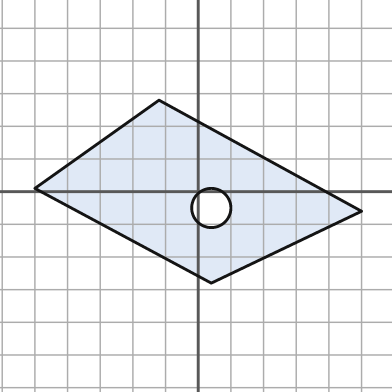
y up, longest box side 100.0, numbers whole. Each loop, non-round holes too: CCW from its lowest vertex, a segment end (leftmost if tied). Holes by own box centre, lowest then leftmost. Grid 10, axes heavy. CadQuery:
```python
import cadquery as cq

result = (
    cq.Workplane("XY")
    .moveTo(4.0, -28.0)
    .lineTo(50.0, -6.0)
    .lineTo(-12.0, 28.0)
    .lineTo(-50.0, 1.0)
    .close()
    .moveTo(4.0, -5.0)
    .circle(6.0)
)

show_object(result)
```